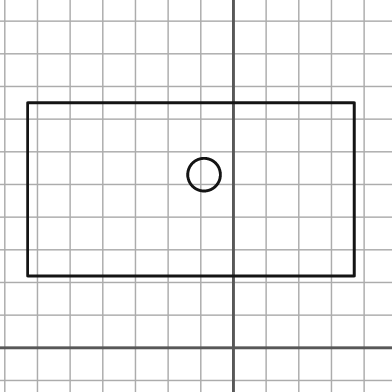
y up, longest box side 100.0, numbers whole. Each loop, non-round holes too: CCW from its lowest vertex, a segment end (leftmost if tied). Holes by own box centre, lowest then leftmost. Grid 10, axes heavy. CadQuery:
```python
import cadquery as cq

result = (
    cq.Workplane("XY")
    .moveTo(-63.0, 22.0)
    .lineTo(37.0, 22.0)
    .lineTo(37.0, 75.0)
    .lineTo(-63.0, 75.0)
    .close()
    .moveTo(-9.0, 53.0)
    .circle(5.0)
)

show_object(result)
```